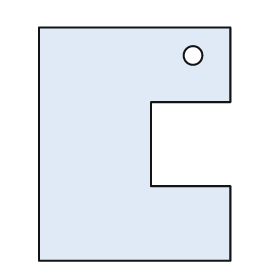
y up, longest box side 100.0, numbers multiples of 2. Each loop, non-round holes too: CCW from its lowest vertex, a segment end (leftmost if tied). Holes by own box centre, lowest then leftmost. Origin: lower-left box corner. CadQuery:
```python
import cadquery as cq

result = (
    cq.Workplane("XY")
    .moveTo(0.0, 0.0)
    .lineTo(82.0, 0.0)
    .lineTo(82.0, 32.0)
    .lineTo(48.0, 32.0)
    .lineTo(48.0, 68.0)
    .lineTo(82.0, 68.0)
    .lineTo(82.0, 100.0)
    .lineTo(0.0, 100.0)
    .close()
    .moveTo(66.0, 88.0)
    .circle(4.0)
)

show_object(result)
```